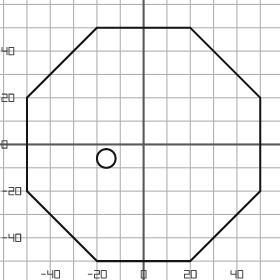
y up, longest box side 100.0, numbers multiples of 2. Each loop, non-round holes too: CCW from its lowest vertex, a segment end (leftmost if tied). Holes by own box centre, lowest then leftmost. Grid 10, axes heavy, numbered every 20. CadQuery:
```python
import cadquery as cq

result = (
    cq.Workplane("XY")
    .moveTo(-20.0, -50.0)
    .lineTo(20.0, -50.0)
    .lineTo(50.0, -20.0)
    .lineTo(50.0, 20.0)
    .lineTo(20.0, 50.0)
    .lineTo(-20.0, 50.0)
    .lineTo(-50.0, 20.0)
    .lineTo(-50.0, -20.0)
    .close()
    .moveTo(-16.0, -6.0)
    .circle(4.0)
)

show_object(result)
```